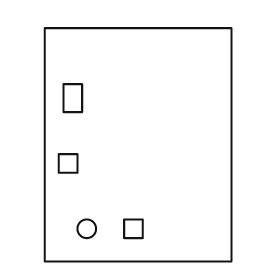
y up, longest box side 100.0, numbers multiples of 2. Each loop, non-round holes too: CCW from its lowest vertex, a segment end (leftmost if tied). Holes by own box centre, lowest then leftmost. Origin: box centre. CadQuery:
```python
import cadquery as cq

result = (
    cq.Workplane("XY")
    .moveTo(-40.0, -50.0)
    .lineTo(40.0, -50.0)
    .lineTo(40.0, 50.0)
    .lineTo(-40.0, 50.0)
    .close()
    .moveTo(-22.0, -36.0)
    .circle(4.0)
    .moveTo(-6.0, -40.0)
    .lineTo(2.0, -40.0)
    .lineTo(2.0, -32.0)
    .lineTo(-6.0, -32.0)
    .close()
    .moveTo(-34.0, -12.0)
    .lineTo(-26.0, -12.0)
    .lineTo(-26.0, -4.0)
    .lineTo(-34.0, -4.0)
    .close()
    .moveTo(-32.0, 14.0)
    .lineTo(-24.0, 14.0)
    .lineTo(-24.0, 26.0)
    .lineTo(-32.0, 26.0)
    .close()
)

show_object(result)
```